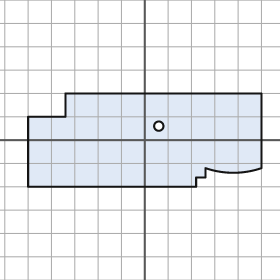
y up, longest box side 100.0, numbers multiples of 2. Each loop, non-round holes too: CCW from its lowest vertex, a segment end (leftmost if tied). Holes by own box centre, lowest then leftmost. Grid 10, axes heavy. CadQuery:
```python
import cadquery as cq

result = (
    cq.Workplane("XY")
    .moveTo(-50.0, -20.0)
    .lineTo(22.0, -20.0)
    .lineTo(22.0, -16.0)
    .lineTo(26.0, -16.0)
    .lineTo(26.0, -12.0)
    .threePointArc((38.0, -14.0), (50.0, -12.0))
    .lineTo(50.0, 20.0)
    .lineTo(-34.0, 20.0)
    .lineTo(-34.0, 10.0)
    .lineTo(-50.0, 10.0)
    .close()
    .moveTo(6.0, 6.0)
    .circle(2.0)
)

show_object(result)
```